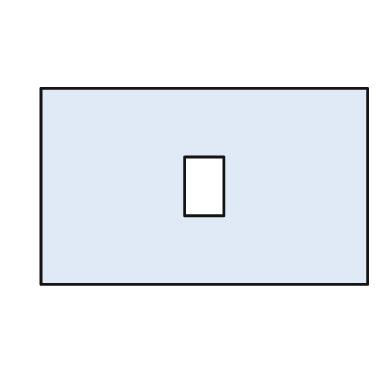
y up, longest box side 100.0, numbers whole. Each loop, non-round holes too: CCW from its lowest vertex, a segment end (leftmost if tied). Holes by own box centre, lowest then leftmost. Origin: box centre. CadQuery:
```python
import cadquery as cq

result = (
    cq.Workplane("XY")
    .moveTo(-50.0, -30.0)
    .lineTo(50.0, -30.0)
    .lineTo(50.0, 30.0)
    .lineTo(-50.0, 30.0)
    .close()
    .moveTo(-6.0, -9.0)
    .lineTo(6.0, -9.0)
    .lineTo(6.0, 9.0)
    .lineTo(-6.0, 9.0)
    .close()
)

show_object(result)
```